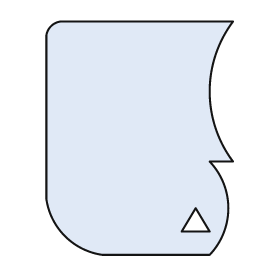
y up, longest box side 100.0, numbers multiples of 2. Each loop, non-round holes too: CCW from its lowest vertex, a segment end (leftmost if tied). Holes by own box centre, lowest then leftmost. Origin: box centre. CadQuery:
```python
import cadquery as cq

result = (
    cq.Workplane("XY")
    .moveTo(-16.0, -50.0)
    .lineTo(30.0, -50.0)
    .threePointArc((38.0, -30.0), (30.0, -10.0))
    .lineTo(40.0, -10.0)
    .threePointArc((30.0, 20.0), (40.0, 50.0))
    .lineTo(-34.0, 50.0)
    .threePointArc((-38.0, 48.0), (-40.0, 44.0))
    .lineTo(-40.0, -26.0)
    .threePointArc((-32.0, -42.0), (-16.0, -50.0))
    .close()
    .moveTo(18.0, -40.0)
    .lineTo(30.0, -40.0)
    .lineTo(24.0, -30.0)
    .close()
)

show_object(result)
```